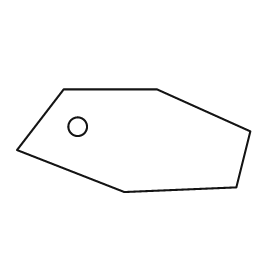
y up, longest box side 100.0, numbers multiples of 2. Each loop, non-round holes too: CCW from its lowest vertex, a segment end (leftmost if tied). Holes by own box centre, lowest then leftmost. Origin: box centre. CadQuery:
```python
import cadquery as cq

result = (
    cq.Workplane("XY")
    .moveTo(-4.0, -22.0)
    .lineTo(44.0, -20.0)
    .lineTo(50.0, 4.0)
    .lineTo(10.0, 22.0)
    .lineTo(-30.0, 22.0)
    .lineTo(-50.0, -4.0)
    .close()
    .moveTo(-24.0, 6.0)
    .circle(4.0)
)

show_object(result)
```